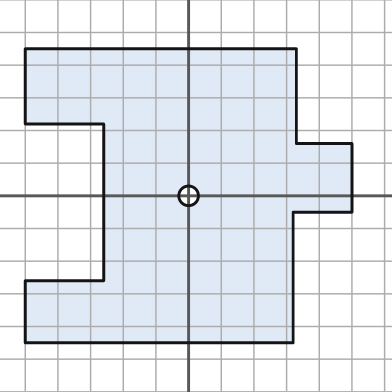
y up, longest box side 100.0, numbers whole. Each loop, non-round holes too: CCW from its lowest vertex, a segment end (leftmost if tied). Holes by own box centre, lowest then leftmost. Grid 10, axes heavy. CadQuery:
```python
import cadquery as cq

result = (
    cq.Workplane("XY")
    .moveTo(-50.0, -45.0)
    .lineTo(32.0, -45.0)
    .lineTo(32.0, -5.0)
    .lineTo(50.0, -5.0)
    .lineTo(50.0, 16.0)
    .lineTo(33.0, 16.0)
    .lineTo(33.0, 45.0)
    .lineTo(-50.0, 45.0)
    .lineTo(-50.0, 22.0)
    .lineTo(-26.0, 22.0)
    .lineTo(-26.0, -26.0)
    .lineTo(-50.0, -26.0)
    .close()
    .moveTo(0.0, 0.0)
    .circle(3.0)
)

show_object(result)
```